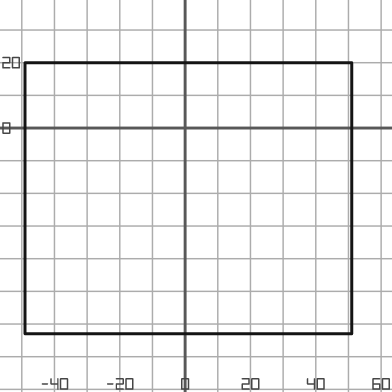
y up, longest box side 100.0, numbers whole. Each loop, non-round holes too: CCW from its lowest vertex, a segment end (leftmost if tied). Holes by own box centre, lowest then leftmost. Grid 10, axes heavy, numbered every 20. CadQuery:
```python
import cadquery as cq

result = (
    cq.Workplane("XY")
    .moveTo(-49.0, -63.0)
    .lineTo(51.0, -63.0)
    .lineTo(51.0, 20.0)
    .lineTo(-49.0, 20.0)
    .close()
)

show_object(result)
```